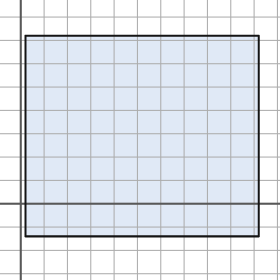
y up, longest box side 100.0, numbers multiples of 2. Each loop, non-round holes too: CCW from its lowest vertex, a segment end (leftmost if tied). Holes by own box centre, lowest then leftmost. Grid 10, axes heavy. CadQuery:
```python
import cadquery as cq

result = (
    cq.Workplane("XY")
    .moveTo(2.0, -14.0)
    .lineTo(102.0, -14.0)
    .lineTo(102.0, 72.0)
    .lineTo(2.0, 72.0)
    .close()
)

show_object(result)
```